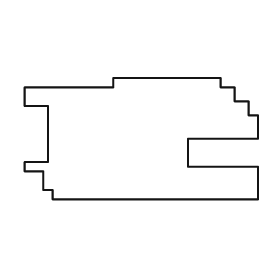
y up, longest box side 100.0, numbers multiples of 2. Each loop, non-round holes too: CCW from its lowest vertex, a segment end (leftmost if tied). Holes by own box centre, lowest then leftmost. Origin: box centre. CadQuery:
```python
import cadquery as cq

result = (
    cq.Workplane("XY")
    .moveTo(-38.0, -26.0)
    .lineTo(50.0, -26.0)
    .lineTo(50.0, -12.0)
    .lineTo(20.0, -12.0)
    .lineTo(20.0, 0.0)
    .lineTo(50.0, 0.0)
    .lineTo(50.0, 10.0)
    .lineTo(46.0, 10.0)
    .lineTo(46.0, 16.0)
    .lineTo(40.0, 16.0)
    .lineTo(40.0, 22.0)
    .lineTo(34.0, 22.0)
    .lineTo(34.0, 26.0)
    .lineTo(-12.0, 26.0)
    .lineTo(-12.0, 22.0)
    .lineTo(-50.0, 22.0)
    .lineTo(-50.0, 14.0)
    .lineTo(-40.0, 14.0)
    .lineTo(-40.0, -10.0)
    .lineTo(-50.0, -10.0)
    .lineTo(-50.0, -14.0)
    .lineTo(-42.0, -14.0)
    .lineTo(-42.0, -22.0)
    .lineTo(-38.0, -22.0)
    .close()
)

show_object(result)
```